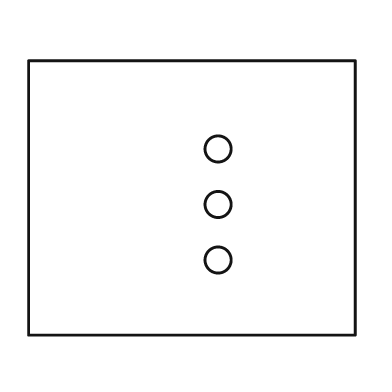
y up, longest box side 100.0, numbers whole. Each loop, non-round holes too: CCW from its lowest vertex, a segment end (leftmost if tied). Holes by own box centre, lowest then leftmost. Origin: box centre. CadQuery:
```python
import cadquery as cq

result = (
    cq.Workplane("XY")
    .moveTo(-50.0, -42.0)
    .lineTo(50.0, -42.0)
    .lineTo(50.0, 42.0)
    .lineTo(-50.0, 42.0)
    .close()
    .moveTo(8.0, -19.0)
    .circle(4.0)
    .moveTo(8.0, -2.0)
    .circle(4.0)
    .moveTo(8.0, 15.0)
    .circle(4.0)
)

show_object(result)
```